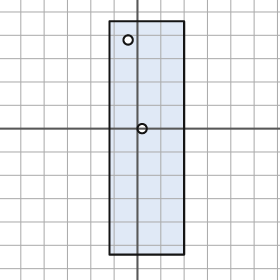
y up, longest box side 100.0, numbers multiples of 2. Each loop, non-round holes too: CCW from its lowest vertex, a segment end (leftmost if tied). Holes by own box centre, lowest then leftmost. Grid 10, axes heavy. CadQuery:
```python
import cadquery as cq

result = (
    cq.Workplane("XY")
    .moveTo(-12.0, -54.0)
    .lineTo(20.0, -54.0)
    .lineTo(20.0, 46.0)
    .lineTo(-12.0, 46.0)
    .close()
    .moveTo(2.0, 0.0)
    .circle(2.0)
    .moveTo(-4.0, 38.0)
    .circle(2.0)
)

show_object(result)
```